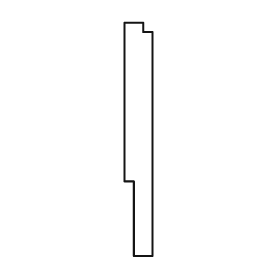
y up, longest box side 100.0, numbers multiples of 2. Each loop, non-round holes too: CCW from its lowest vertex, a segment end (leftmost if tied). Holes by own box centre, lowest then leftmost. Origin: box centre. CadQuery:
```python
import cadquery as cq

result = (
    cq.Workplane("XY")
    .moveTo(-2.0, -50.0)
    .lineTo(6.0, -50.0)
    .lineTo(6.0, 46.0)
    .lineTo(2.0, 46.0)
    .lineTo(2.0, 50.0)
    .lineTo(-6.0, 50.0)
    .lineTo(-6.0, -18.0)
    .lineTo(-2.0, -18.0)
    .close()
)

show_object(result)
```